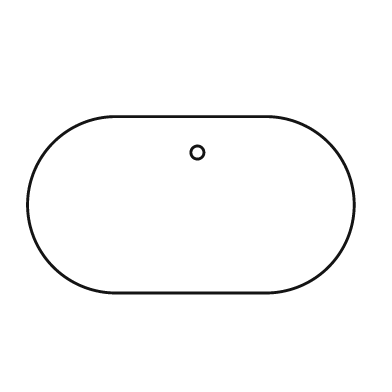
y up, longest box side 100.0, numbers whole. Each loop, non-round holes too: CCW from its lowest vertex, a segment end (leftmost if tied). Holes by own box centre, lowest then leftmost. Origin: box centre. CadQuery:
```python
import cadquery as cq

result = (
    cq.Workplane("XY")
    .moveTo(-23.0, -27.0)
    .lineTo(23.0, -27.0)
    .threePointArc((50.0, 0.0), (23.0, 27.0))
    .lineTo(-23.0, 27.0)
    .threePointArc((-50.0, 0.0), (-23.0, -27.0))
    .close()
    .moveTo(2.0, 16.0)
    .circle(2.0)
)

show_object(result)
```